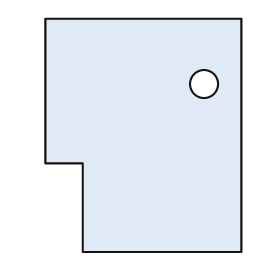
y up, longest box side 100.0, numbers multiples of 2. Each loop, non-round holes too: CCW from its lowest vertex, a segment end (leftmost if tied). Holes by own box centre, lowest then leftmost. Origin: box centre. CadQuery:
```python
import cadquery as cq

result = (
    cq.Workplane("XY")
    .moveTo(-26.0, -50.0)
    .lineTo(42.0, -50.0)
    .lineTo(42.0, 50.0)
    .lineTo(-42.0, 50.0)
    .lineTo(-42.0, -12.0)
    .lineTo(-26.0, -12.0)
    .close()
    .moveTo(26.0, 22.0)
    .circle(6.0)
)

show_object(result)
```